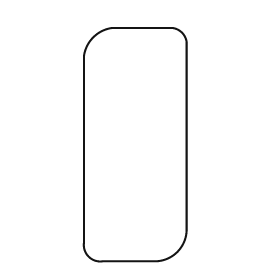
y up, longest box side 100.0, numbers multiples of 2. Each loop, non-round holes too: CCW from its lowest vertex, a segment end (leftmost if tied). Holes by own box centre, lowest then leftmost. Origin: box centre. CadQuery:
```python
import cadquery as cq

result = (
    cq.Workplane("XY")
    .moveTo(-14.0, -50.0)
    .lineTo(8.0, -50.0)
    .threePointArc((18.0, -46.0), (22.0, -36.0))
    .lineTo(22.0, 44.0)
    .threePointArc((20.0, 48.0), (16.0, 50.0))
    .lineTo(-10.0, 50.0)
    .threePointArc((-18.0, 46.0), (-22.0, 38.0))
    .lineTo(-22.0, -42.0)
    .threePointArc((-20.0, -48.0), (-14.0, -50.0))
    .close()
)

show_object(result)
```